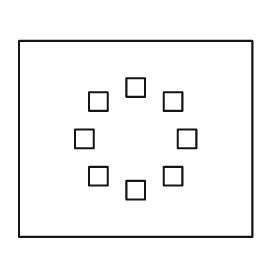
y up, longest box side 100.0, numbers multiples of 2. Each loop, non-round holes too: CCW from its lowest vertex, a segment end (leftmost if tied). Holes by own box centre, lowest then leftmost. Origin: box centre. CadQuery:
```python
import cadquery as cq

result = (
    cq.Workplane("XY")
    .moveTo(-50.0, -42.0)
    .lineTo(50.0, -42.0)
    .lineTo(50.0, 42.0)
    .lineTo(-50.0, 42.0)
    .close()
    .moveTo(-4.0, -26.0)
    .lineTo(4.0, -26.0)
    .lineTo(4.0, -18.0)
    .lineTo(-4.0, -18.0)
    .close()
    .moveTo(-20.0, -20.0)
    .lineTo(-12.0, -20.0)
    .lineTo(-12.0, -12.0)
    .lineTo(-20.0, -12.0)
    .close()
    .moveTo(12.0, -20.0)
    .lineTo(20.0, -20.0)
    .lineTo(20.0, -12.0)
    .lineTo(12.0, -12.0)
    .close()
    .moveTo(-26.0, -4.0)
    .lineTo(-18.0, -4.0)
    .lineTo(-18.0, 4.0)
    .lineTo(-26.0, 4.0)
    .close()
    .moveTo(18.0, -4.0)
    .lineTo(26.0, -4.0)
    .lineTo(26.0, 4.0)
    .lineTo(18.0, 4.0)
    .close()
    .moveTo(-20.0, 12.0)
    .lineTo(-12.0, 12.0)
    .lineTo(-12.0, 20.0)
    .lineTo(-20.0, 20.0)
    .close()
    .moveTo(12.0, 12.0)
    .lineTo(20.0, 12.0)
    .lineTo(20.0, 20.0)
    .lineTo(12.0, 20.0)
    .close()
    .moveTo(-4.0, 18.0)
    .lineTo(4.0, 18.0)
    .lineTo(4.0, 26.0)
    .lineTo(-4.0, 26.0)
    .close()
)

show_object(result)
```